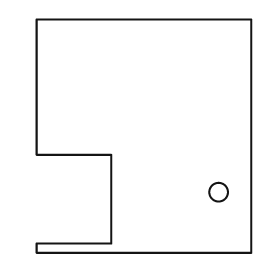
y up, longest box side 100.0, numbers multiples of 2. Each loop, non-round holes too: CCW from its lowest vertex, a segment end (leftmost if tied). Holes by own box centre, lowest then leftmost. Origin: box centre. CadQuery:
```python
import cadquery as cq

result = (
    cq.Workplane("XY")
    .moveTo(-46.0, -50.0)
    .lineTo(46.0, -50.0)
    .lineTo(46.0, 50.0)
    .lineTo(-46.0, 50.0)
    .lineTo(-46.0, -8.0)
    .lineTo(-14.0, -8.0)
    .lineTo(-14.0, -46.0)
    .lineTo(-46.0, -46.0)
    .close()
    .moveTo(32.0, -24.0)
    .circle(4.0)
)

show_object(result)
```